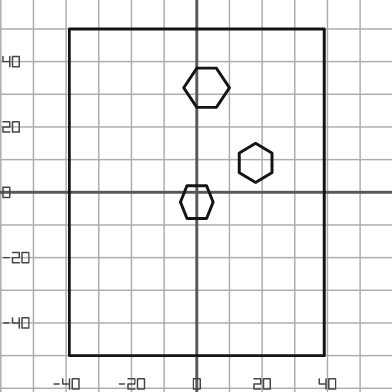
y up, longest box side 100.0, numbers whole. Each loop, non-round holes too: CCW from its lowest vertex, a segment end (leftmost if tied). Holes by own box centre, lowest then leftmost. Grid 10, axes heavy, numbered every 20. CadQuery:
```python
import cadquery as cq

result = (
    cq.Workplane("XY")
    .moveTo(-39.0, -50.0)
    .lineTo(39.0, -50.0)
    .lineTo(39.0, 50.0)
    .lineTo(-39.0, 50.0)
    .close()
    .moveTo(-3.0, -8.0)
    .lineTo(3.0, -8.0)
    .lineTo(5.0, -3.0)
    .lineTo(3.0, 2.0)
    .lineTo(-3.0, 2.0)
    .lineTo(-5.0, -3.0)
    .close()
    .moveTo(18.0, 3.0)
    .lineTo(23.0, 6.0)
    .lineTo(23.0, 12.0)
    .lineTo(18.0, 15.0)
    .lineTo(13.0, 12.0)
    .lineTo(13.0, 6.0)
    .close()
    .moveTo(0.0, 26.0)
    .lineTo(6.0, 26.0)
    .lineTo(10.0, 32.0)
    .lineTo(6.0, 38.0)
    .lineTo(0.0, 38.0)
    .lineTo(-4.0, 32.0)
    .close()
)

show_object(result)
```